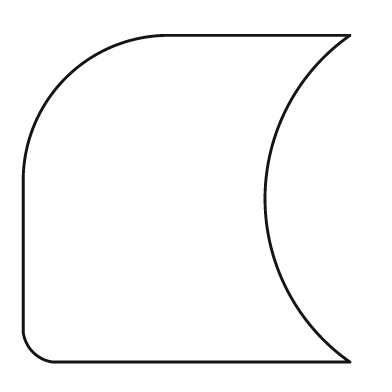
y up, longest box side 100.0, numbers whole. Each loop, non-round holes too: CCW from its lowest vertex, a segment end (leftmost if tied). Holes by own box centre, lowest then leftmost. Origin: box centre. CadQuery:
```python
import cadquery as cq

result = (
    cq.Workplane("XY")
    .moveTo(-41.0, -50.0)
    .lineTo(50.0, -50.0)
    .threePointArc((24.0, 0.0), (50.0, 50.0))
    .lineTo(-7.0, 50.0)
    .threePointArc((-37.0, 37.0), (-50.0, 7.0))
    .lineTo(-50.0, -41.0)
    .threePointArc((-47.0, -47.0), (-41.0, -50.0))
    .close()
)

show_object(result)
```